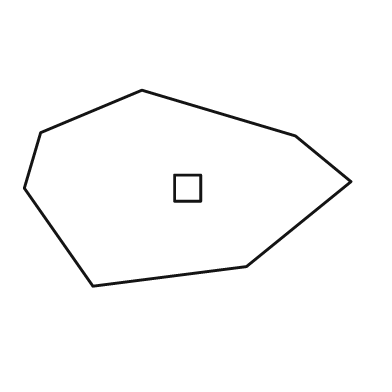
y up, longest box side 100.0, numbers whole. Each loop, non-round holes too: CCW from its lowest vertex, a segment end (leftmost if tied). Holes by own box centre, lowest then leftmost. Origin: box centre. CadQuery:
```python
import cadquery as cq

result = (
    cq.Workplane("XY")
    .moveTo(-29.0, -30.0)
    .lineTo(18.0, -24.0)
    .lineTo(50.0, 2.0)
    .lineTo(33.0, 16.0)
    .lineTo(-14.0, 30.0)
    .lineTo(-45.0, 17.0)
    .lineTo(-50.0, 0.0)
    .close()
    .moveTo(-4.0, -4.0)
    .lineTo(4.0, -4.0)
    .lineTo(4.0, 4.0)
    .lineTo(-4.0, 4.0)
    .close()
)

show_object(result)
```